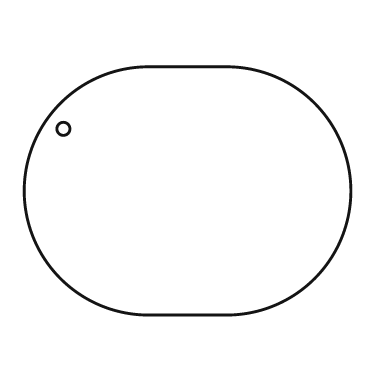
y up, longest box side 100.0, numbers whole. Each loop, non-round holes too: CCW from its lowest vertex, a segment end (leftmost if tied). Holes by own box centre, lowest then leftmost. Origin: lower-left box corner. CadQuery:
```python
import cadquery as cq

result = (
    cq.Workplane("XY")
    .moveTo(38.0, 0.0)
    .lineTo(62.0, 0.0)
    .threePointArc((100.0, 38.0), (62.0, 76.0))
    .lineTo(38.0, 76.0)
    .threePointArc((0.0, 38.0), (38.0, 0.0))
    .close()
    .moveTo(12.0, 57.0)
    .circle(2.0)
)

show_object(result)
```